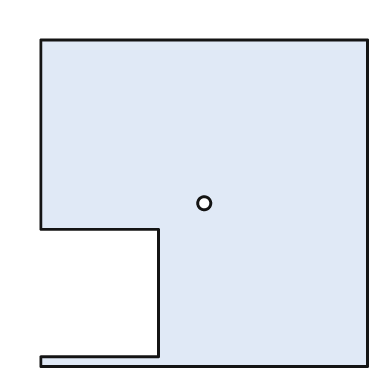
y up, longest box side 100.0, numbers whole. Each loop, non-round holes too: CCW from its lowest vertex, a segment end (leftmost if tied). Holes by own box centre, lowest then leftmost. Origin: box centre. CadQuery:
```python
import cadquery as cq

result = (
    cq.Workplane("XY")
    .moveTo(-50.0, -50.0)
    .lineTo(50.0, -50.0)
    .lineTo(50.0, 50.0)
    .lineTo(-50.0, 50.0)
    .lineTo(-50.0, -8.0)
    .lineTo(-14.0, -8.0)
    .lineTo(-14.0, -47.0)
    .lineTo(-50.0, -47.0)
    .close()
    .moveTo(0.0, 0.0)
    .circle(2.0)
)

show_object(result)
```